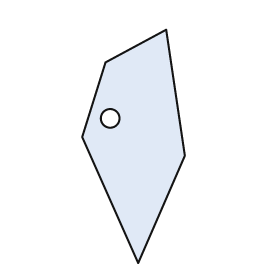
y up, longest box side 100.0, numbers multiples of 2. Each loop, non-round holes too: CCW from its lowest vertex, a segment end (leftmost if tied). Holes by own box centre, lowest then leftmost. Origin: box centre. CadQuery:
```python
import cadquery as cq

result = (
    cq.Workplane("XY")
    .moveTo(2.0, -50.0)
    .lineTo(22.0, -4.0)
    .lineTo(14.0, 50.0)
    .lineTo(-12.0, 36.0)
    .lineTo(-22.0, 4.0)
    .close()
    .moveTo(-10.0, 12.0)
    .circle(4.0)
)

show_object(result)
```